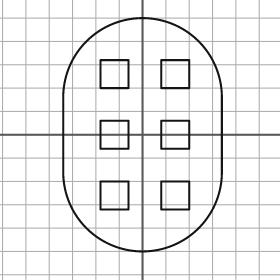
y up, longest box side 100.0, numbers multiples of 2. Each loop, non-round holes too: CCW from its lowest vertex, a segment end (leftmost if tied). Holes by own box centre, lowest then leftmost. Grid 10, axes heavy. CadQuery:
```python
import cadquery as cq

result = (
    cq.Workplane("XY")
    .moveTo(-34.0, -16.0)
    .threePointArc((0.0, -50.0), (34.0, -16.0))
    .lineTo(34.0, 16.0)
    .threePointArc((0.0, 50.0), (-34.0, 16.0))
    .close()
    .moveTo(-18.0, -32.0)
    .lineTo(-6.0, -32.0)
    .lineTo(-6.0, -20.0)
    .lineTo(-18.0, -20.0)
    .close()
    .moveTo(8.0, -32.0)
    .lineTo(20.0, -32.0)
    .lineTo(20.0, -20.0)
    .lineTo(8.0, -20.0)
    .close()
    .moveTo(-18.0, -6.0)
    .lineTo(-6.0, -6.0)
    .lineTo(-6.0, 6.0)
    .lineTo(-18.0, 6.0)
    .close()
    .moveTo(8.0, -6.0)
    .lineTo(20.0, -6.0)
    .lineTo(20.0, 6.0)
    .lineTo(8.0, 6.0)
    .close()
    .moveTo(-18.0, 20.0)
    .lineTo(-6.0, 20.0)
    .lineTo(-6.0, 32.0)
    .lineTo(-18.0, 32.0)
    .close()
    .moveTo(8.0, 20.0)
    .lineTo(20.0, 20.0)
    .lineTo(20.0, 32.0)
    .lineTo(8.0, 32.0)
    .close()
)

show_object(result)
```